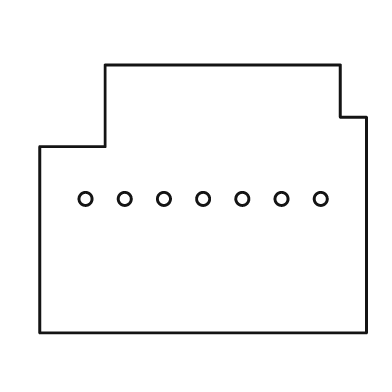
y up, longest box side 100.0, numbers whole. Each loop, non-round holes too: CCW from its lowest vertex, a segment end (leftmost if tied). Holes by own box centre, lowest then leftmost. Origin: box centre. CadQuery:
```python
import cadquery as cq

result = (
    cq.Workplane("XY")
    .moveTo(-50.0, -41.0)
    .lineTo(50.0, -41.0)
    .lineTo(50.0, 25.0)
    .lineTo(42.0, 25.0)
    .lineTo(42.0, 41.0)
    .lineTo(-30.0, 41.0)
    .lineTo(-30.0, 16.0)
    .lineTo(-50.0, 16.0)
    .close()
    .moveTo(-36.0, 0.0)
    .circle(2.0)
    .moveTo(-24.0, 0.0)
    .circle(2.0)
    .moveTo(-12.0, 0.0)
    .circle(2.0)
    .moveTo(0.0, 0.0)
    .circle(2.0)
    .moveTo(12.0, 0.0)
    .circle(2.0)
    .moveTo(24.0, 0.0)
    .circle(2.0)
    .moveTo(36.0, 0.0)
    .circle(2.0)
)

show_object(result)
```